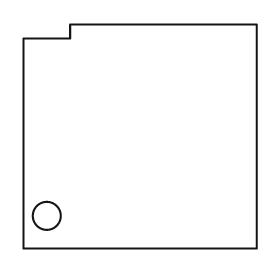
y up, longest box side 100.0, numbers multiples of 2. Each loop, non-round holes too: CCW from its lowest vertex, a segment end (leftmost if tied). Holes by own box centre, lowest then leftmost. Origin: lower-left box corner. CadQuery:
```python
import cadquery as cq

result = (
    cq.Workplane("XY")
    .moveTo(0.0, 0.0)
    .lineTo(100.0, 0.0)
    .lineTo(100.0, 96.0)
    .lineTo(20.0, 96.0)
    .lineTo(20.0, 90.0)
    .lineTo(0.0, 90.0)
    .close()
    .moveTo(10.0, 14.0)
    .circle(6.0)
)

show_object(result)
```